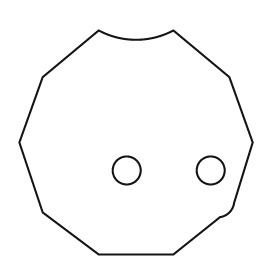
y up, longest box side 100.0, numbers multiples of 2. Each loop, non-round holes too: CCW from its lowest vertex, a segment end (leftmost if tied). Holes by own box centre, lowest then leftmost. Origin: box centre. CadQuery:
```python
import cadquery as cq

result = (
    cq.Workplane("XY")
    .moveTo(-16.0, -48.0)
    .lineTo(16.0, -48.0)
    .lineTo(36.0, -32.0)
    .threePointArc((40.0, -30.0), (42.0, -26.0))
    .lineTo(50.0, 0.0)
    .lineTo(40.0, 28.0)
    .lineTo(16.0, 48.0)
    .threePointArc((0.0, 44.0), (-16.0, 48.0))
    .lineTo(-40.0, 28.0)
    .lineTo(-50.0, 0.0)
    .lineTo(-40.0, -30.0)
    .close()
    .moveTo(-4.0, -12.0)
    .circle(6.0)
    .moveTo(32.0, -12.0)
    .circle(6.0)
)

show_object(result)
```